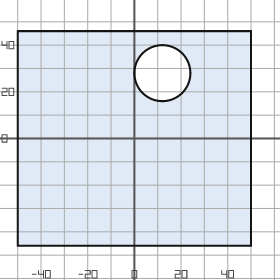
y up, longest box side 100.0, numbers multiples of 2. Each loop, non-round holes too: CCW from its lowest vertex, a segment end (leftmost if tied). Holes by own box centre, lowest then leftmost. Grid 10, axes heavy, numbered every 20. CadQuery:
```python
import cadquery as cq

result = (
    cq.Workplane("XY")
    .moveTo(-50.0, -46.0)
    .lineTo(50.0, -46.0)
    .lineTo(50.0, 46.0)
    .lineTo(-50.0, 46.0)
    .close()
    .moveTo(12.0, 28.0)
    .circle(12.0)
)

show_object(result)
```